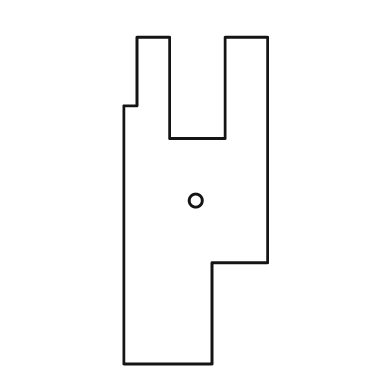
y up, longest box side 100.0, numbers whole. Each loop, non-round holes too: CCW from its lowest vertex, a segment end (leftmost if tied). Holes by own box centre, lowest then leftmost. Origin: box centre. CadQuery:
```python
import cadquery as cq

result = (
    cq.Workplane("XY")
    .moveTo(-22.0, -50.0)
    .lineTo(5.0, -50.0)
    .lineTo(5.0, -19.0)
    .lineTo(22.0, -19.0)
    .lineTo(22.0, 50.0)
    .lineTo(9.0, 50.0)
    .lineTo(9.0, 19.0)
    .lineTo(-8.0, 19.0)
    .lineTo(-8.0, 50.0)
    .lineTo(-18.0, 50.0)
    .lineTo(-18.0, 29.0)
    .lineTo(-22.0, 29.0)
    .close()
    .moveTo(0.0, 0.0)
    .circle(2.0)
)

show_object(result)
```